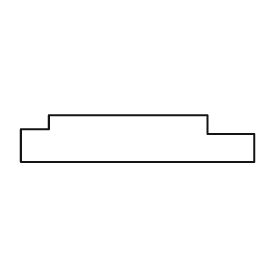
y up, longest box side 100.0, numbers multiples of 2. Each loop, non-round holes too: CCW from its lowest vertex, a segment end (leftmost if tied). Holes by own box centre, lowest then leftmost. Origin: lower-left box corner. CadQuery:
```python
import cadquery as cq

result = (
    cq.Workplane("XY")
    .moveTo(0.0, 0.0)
    .lineTo(100.0, 0.0)
    .lineTo(100.0, 12.0)
    .lineTo(80.0, 12.0)
    .lineTo(80.0, 20.0)
    .lineTo(12.0, 20.0)
    .lineTo(12.0, 14.0)
    .lineTo(0.0, 14.0)
    .close()
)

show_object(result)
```